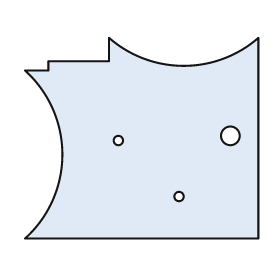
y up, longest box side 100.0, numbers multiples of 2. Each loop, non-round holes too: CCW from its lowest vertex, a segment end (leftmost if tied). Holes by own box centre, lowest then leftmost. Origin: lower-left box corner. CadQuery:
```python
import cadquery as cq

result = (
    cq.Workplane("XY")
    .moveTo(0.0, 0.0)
    .lineTo(100.0, 0.0)
    .lineTo(100.0, 86.0)
    .threePointArc((68.0, 74.0), (36.0, 86.0))
    .lineTo(36.0, 76.0)
    .lineTo(10.0, 76.0)
    .lineTo(10.0, 72.0)
    .lineTo(0.0, 72.0)
    .threePointArc((16.0, 36.0), (0.0, 0.0))
    .close()
    .moveTo(66.0, 18.0)
    .circle(2.0)
    .moveTo(40.0, 42.0)
    .circle(2.0)
    .moveTo(88.0, 44.0)
    .circle(4.0)
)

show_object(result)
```